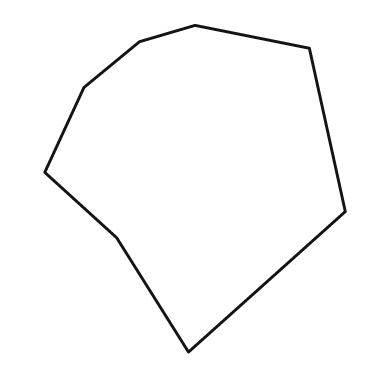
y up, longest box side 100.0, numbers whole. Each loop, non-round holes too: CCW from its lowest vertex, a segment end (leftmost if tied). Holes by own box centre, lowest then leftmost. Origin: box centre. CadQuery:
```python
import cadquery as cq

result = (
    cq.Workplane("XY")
    .moveTo(-2.0, -50.0)
    .lineTo(46.0, -7.0)
    .lineTo(35.0, 43.0)
    .lineTo(0.0, 50.0)
    .lineTo(-17.0, 45.0)
    .lineTo(-34.0, 31.0)
    .lineTo(-46.0, 5.0)
    .lineTo(-24.0, -15.0)
    .close()
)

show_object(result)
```